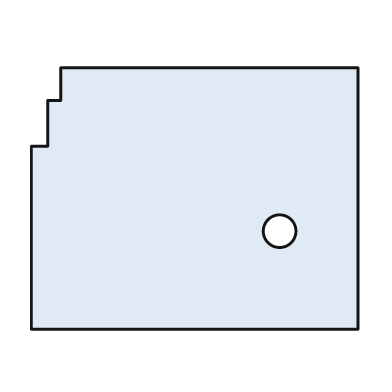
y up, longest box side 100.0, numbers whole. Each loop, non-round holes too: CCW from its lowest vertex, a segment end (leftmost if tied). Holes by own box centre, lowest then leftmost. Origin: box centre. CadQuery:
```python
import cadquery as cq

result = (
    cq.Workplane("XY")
    .moveTo(-50.0, -40.0)
    .lineTo(50.0, -40.0)
    .lineTo(50.0, 40.0)
    .lineTo(-41.0, 40.0)
    .lineTo(-41.0, 30.0)
    .lineTo(-45.0, 30.0)
    .lineTo(-45.0, 16.0)
    .lineTo(-50.0, 16.0)
    .close()
    .moveTo(26.0, -10.0)
    .circle(5.0)
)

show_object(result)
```